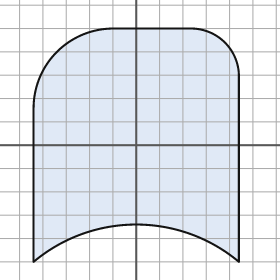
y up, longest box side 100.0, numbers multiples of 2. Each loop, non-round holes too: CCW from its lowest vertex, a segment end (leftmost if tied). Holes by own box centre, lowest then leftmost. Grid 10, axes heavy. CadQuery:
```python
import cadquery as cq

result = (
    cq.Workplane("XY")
    .moveTo(-44.0, -50.0)
    .threePointArc((0.0, -34.0), (44.0, -50.0))
    .lineTo(44.0, 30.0)
    .threePointArc((38.0, 44.0), (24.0, 50.0))
    .lineTo(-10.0, 50.0)
    .threePointArc((-34.0, 40.0), (-44.0, 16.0))
    .close()
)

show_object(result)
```